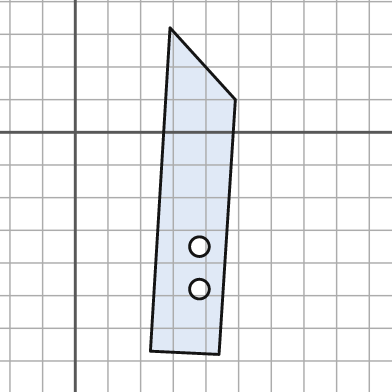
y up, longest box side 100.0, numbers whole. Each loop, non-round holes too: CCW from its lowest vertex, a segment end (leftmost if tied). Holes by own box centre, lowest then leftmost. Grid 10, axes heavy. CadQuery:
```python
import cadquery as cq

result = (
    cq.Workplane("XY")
    .moveTo(44.0, -68.0)
    .lineTo(49.0, 10.0)
    .lineTo(29.0, 32.0)
    .lineTo(23.0, -67.0)
    .close()
    .moveTo(38.0, -48.0)
    .circle(3.0)
    .moveTo(38.0, -35.0)
    .circle(3.0)
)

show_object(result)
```